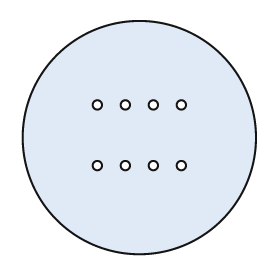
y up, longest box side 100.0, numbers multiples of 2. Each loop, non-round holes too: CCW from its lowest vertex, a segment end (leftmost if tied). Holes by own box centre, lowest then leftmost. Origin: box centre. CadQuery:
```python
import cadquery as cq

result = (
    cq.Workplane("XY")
    .moveTo(0.0, 0.0)
    .circle(50.0)
    .moveTo(-18.0, -12.0)
    .circle(2.0)
    .moveTo(-6.0, -12.0)
    .circle(2.0)
    .moveTo(6.0, -12.0)
    .circle(2.0)
    .moveTo(18.0, -12.0)
    .circle(2.0)
    .moveTo(-18.0, 14.0)
    .circle(2.0)
    .moveTo(-6.0, 14.0)
    .circle(2.0)
    .moveTo(6.0, 14.0)
    .circle(2.0)
    .moveTo(18.0, 14.0)
    .circle(2.0)
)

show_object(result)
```